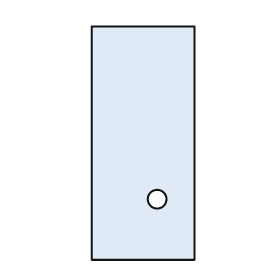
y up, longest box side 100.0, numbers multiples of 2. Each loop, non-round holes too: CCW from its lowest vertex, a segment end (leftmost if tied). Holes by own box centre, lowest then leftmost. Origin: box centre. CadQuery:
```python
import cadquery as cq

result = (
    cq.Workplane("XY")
    .moveTo(-22.0, -50.0)
    .lineTo(22.0, -50.0)
    .lineTo(22.0, 50.0)
    .lineTo(-22.0, 50.0)
    .close()
    .moveTo(6.0, -24.0)
    .circle(4.0)
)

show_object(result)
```